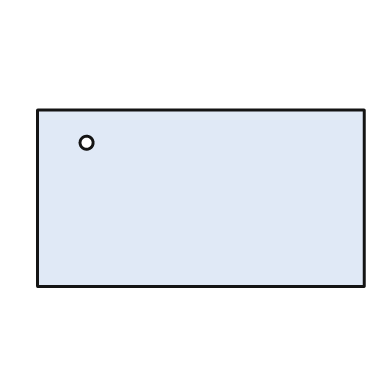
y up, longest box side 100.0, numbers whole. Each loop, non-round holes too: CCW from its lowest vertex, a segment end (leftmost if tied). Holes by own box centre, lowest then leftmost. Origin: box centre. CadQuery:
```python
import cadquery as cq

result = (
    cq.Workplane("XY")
    .moveTo(-50.0, -27.0)
    .lineTo(50.0, -27.0)
    .lineTo(50.0, 27.0)
    .lineTo(-50.0, 27.0)
    .close()
    .moveTo(-35.0, 17.0)
    .circle(2.0)
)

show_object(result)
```